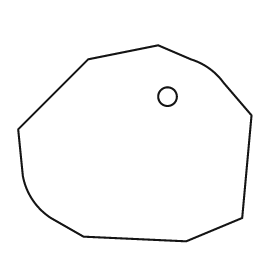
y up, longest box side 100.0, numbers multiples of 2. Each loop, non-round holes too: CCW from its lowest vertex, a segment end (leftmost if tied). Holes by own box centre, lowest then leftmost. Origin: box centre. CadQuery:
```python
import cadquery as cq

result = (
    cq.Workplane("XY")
    .moveTo(22.0, -42.0)
    .lineTo(46.0, -32.0)
    .lineTo(50.0, 12.0)
    .lineTo(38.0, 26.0)
    .threePointArc((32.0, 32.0), (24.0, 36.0))
    .lineTo(10.0, 42.0)
    .lineTo(-20.0, 36.0)
    .lineTo(-50.0, 6.0)
    .lineTo(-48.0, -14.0)
    .threePointArc((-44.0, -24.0), (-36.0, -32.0))
    .lineTo(-22.0, -40.0)
    .close()
    .moveTo(14.0, 20.0)
    .circle(4.0)
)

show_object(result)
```